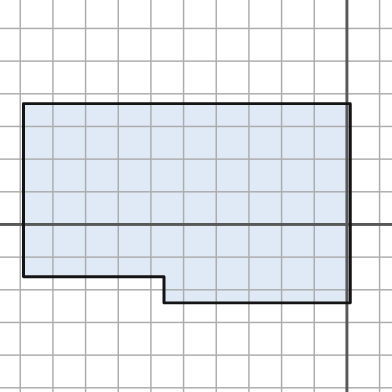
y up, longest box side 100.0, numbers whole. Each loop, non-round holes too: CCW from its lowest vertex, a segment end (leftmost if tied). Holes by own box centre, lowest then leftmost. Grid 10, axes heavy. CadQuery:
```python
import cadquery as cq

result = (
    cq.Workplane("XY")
    .moveTo(-56.0, -24.0)
    .lineTo(1.0, -24.0)
    .lineTo(1.0, 37.0)
    .lineTo(-99.0, 37.0)
    .lineTo(-99.0, -16.0)
    .lineTo(-56.0, -16.0)
    .close()
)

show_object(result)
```